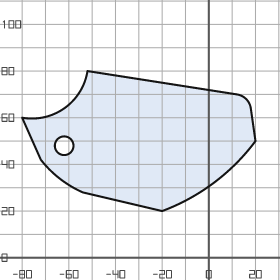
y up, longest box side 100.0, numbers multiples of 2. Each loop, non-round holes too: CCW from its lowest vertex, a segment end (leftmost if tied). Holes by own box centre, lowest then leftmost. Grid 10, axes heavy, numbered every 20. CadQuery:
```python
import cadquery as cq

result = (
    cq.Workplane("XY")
    .moveTo(-20.0, 20.0)
    .threePointArc((2.0, 32.0), (20.0, 50.0))
    .lineTo(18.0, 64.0)
    .threePointArc((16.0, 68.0), (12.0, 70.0))
    .lineTo(-52.0, 80.0)
    .threePointArc((-62.0, 64.0), (-80.0, 60.0))
    .lineTo(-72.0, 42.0)
    .threePointArc((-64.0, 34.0), (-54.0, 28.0))
    .close()
    .moveTo(-62.0, 48.0)
    .circle(4.0)
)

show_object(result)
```